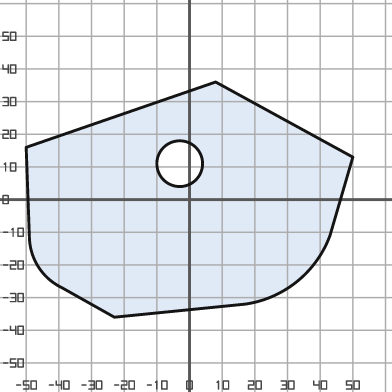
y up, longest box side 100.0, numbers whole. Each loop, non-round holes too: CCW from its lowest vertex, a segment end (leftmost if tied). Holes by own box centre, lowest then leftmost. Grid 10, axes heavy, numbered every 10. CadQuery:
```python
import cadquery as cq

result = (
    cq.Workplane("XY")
    .moveTo(-23.0, -36.0)
    .lineTo(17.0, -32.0)
    .threePointArc((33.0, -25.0), (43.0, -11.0))
    .lineTo(50.0, 13.0)
    .lineTo(8.0, 36.0)
    .lineTo(-50.0, 16.0)
    .lineTo(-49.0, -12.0)
    .threePointArc((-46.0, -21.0), (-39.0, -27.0))
    .close()
    .moveTo(-3.0, 11.0)
    .circle(7.0)
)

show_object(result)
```